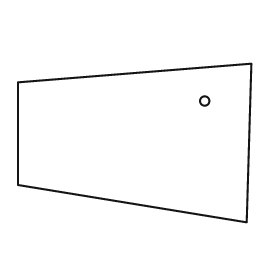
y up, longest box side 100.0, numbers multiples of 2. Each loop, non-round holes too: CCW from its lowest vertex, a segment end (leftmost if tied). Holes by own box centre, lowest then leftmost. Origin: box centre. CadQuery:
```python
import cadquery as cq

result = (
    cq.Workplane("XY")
    .moveTo(48.0, -34.0)
    .lineTo(50.0, 34.0)
    .lineTo(-50.0, 26.0)
    .lineTo(-50.0, -18.0)
    .close()
    .moveTo(30.0, 18.0)
    .circle(2.0)
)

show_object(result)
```